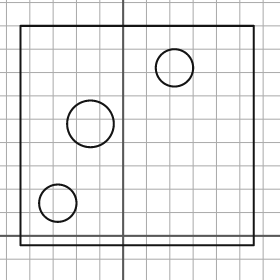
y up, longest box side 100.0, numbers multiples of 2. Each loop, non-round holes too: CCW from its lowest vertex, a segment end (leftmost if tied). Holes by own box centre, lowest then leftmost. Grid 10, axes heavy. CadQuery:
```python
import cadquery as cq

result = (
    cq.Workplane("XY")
    .moveTo(-44.0, -4.0)
    .lineTo(56.0, -4.0)
    .lineTo(56.0, 90.0)
    .lineTo(-44.0, 90.0)
    .close()
    .moveTo(-28.0, 14.0)
    .circle(8.0)
    .moveTo(-14.0, 48.0)
    .circle(10.0)
    .moveTo(22.0, 72.0)
    .circle(8.0)
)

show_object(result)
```